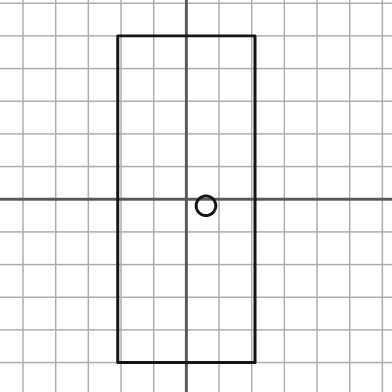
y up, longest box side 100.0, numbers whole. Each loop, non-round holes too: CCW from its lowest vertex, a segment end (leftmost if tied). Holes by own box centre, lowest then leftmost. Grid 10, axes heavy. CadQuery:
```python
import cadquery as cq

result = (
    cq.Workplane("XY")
    .moveTo(-21.0, -50.0)
    .lineTo(21.0, -50.0)
    .lineTo(21.0, 50.0)
    .lineTo(-21.0, 50.0)
    .close()
    .moveTo(6.0, -2.0)
    .circle(3.0)
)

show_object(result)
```